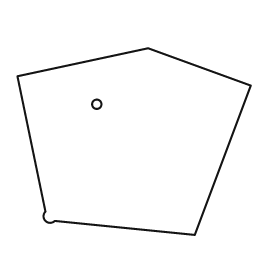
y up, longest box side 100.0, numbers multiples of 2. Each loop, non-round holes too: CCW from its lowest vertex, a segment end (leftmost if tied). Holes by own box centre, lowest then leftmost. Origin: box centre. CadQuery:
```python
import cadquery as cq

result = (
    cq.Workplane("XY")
    .moveTo(26.0, -40.0)
    .lineTo(50.0, 24.0)
    .lineTo(6.0, 40.0)
    .lineTo(-50.0, 28.0)
    .lineTo(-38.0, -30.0)
    .threePointArc((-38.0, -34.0), (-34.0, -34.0))
    .close()
    .moveTo(-16.0, 16.0)
    .circle(2.0)
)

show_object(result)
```